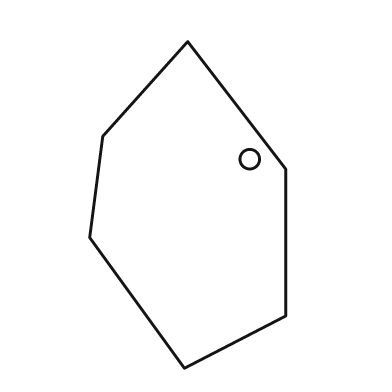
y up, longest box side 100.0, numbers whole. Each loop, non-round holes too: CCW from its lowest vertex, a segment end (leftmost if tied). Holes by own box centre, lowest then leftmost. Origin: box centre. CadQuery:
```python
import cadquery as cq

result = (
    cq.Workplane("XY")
    .moveTo(-1.0, -50.0)
    .lineTo(30.0, -34.0)
    .lineTo(30.0, 11.0)
    .lineTo(0.0, 50.0)
    .lineTo(-26.0, 21.0)
    .lineTo(-30.0, -10.0)
    .close()
    .moveTo(19.0, 14.0)
    .circle(3.0)
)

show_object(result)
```